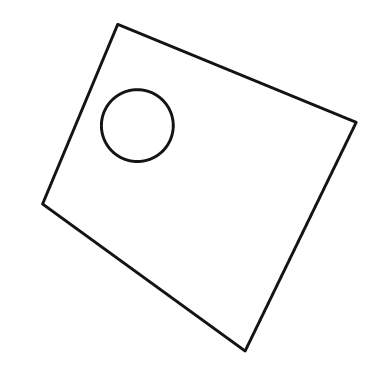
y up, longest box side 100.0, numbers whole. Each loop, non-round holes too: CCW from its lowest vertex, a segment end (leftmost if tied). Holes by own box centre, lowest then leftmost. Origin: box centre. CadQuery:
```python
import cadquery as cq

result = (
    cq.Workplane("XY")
    .moveTo(14.0, -50.0)
    .lineTo(48.0, 20.0)
    .lineTo(-25.0, 50.0)
    .lineTo(-48.0, -5.0)
    .close()
    .moveTo(-19.0, 19.0)
    .circle(11.0)
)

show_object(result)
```